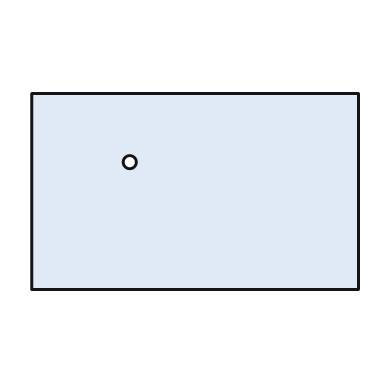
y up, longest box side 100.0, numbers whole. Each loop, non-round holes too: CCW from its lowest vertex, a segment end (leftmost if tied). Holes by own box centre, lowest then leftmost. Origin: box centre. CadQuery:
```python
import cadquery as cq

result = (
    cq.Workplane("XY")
    .moveTo(-50.0, -30.0)
    .lineTo(50.0, -30.0)
    .lineTo(50.0, 30.0)
    .lineTo(-50.0, 30.0)
    .close()
    .moveTo(-20.0, 9.0)
    .circle(2.0)
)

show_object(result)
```